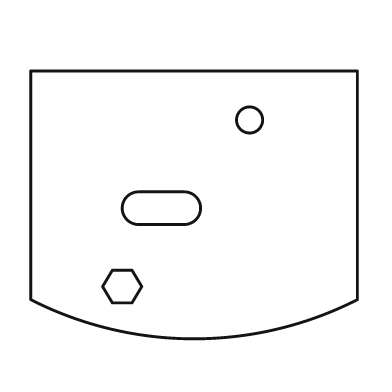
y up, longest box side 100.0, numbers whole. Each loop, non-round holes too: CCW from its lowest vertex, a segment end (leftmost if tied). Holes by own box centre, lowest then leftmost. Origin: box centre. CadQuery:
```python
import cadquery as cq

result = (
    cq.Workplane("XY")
    .moveTo(-50.0, -29.0)
    .threePointArc((0.0, -41.0), (50.0, -29.0))
    .lineTo(50.0, 41.0)
    .lineTo(-50.0, 41.0)
    .close()
    .moveTo(-25.0, -30.0)
    .lineTo(-19.0, -30.0)
    .lineTo(-16.0, -25.0)
    .lineTo(-19.0, -20.0)
    .lineTo(-25.0, -20.0)
    .lineTo(-28.0, -25.0)
    .close()
    .moveTo(-17.0, -6.0)
    .lineTo(-3.0, -6.0)
    .threePointArc((2.0, -1.0), (-3.0, 4.0))
    .lineTo(-17.0, 4.0)
    .threePointArc((-22.0, -1.0), (-17.0, -6.0))
    .close()
    .moveTo(17.0, 26.0)
    .circle(4.0)
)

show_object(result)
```